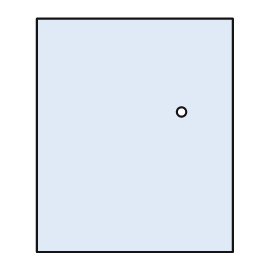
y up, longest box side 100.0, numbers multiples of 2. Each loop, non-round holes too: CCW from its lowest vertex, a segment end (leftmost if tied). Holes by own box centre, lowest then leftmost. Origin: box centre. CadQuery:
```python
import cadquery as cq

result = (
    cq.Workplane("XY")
    .moveTo(-42.0, -50.0)
    .lineTo(42.0, -50.0)
    .lineTo(42.0, 50.0)
    .lineTo(-42.0, 50.0)
    .close()
    .moveTo(20.0, 10.0)
    .circle(2.0)
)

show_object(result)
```